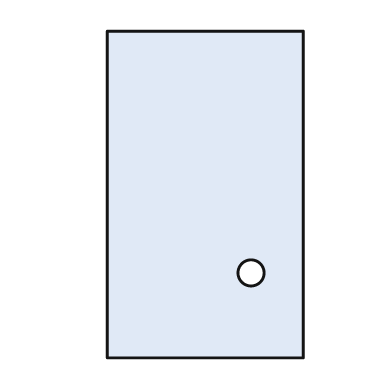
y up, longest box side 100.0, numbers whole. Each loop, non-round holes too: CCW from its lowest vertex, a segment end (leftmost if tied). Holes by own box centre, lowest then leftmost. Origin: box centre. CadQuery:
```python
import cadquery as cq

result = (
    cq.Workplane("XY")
    .moveTo(-30.0, -50.0)
    .lineTo(30.0, -50.0)
    .lineTo(30.0, 50.0)
    .lineTo(-30.0, 50.0)
    .close()
    .moveTo(14.0, -24.0)
    .circle(4.0)
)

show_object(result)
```